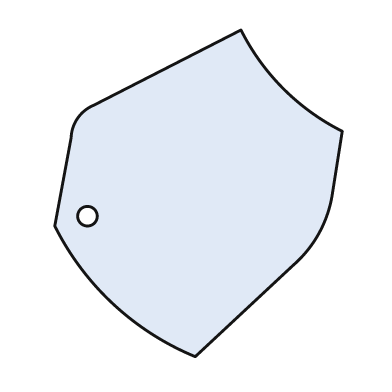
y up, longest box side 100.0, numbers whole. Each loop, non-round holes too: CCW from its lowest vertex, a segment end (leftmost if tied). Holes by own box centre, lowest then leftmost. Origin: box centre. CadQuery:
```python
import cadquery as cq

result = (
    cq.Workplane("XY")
    .moveTo(-1.0, -50.0)
    .lineTo(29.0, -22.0)
    .threePointArc((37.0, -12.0), (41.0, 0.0))
    .lineTo(44.0, 19.0)
    .threePointArc((26.0, 32.0), (13.0, 50.0))
    .lineTo(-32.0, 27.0)
    .threePointArc((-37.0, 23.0), (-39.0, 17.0))
    .lineTo(-44.0, -10.0)
    .threePointArc((-26.0, -34.0), (-1.0, -50.0))
    .close()
    .moveTo(-34.0, -7.0)
    .circle(3.0)
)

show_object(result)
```